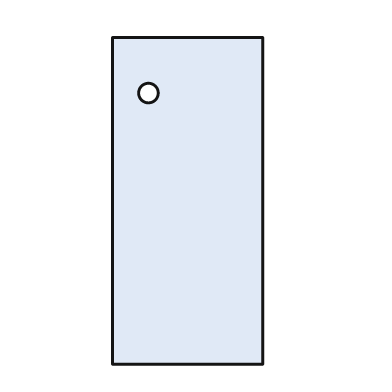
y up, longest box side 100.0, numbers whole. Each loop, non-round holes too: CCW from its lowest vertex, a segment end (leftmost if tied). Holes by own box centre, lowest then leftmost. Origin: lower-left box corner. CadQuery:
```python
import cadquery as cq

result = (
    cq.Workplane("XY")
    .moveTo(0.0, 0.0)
    .lineTo(46.0, 0.0)
    .lineTo(46.0, 100.0)
    .lineTo(0.0, 100.0)
    .close()
    .moveTo(11.0, 83.0)
    .circle(3.0)
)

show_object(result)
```